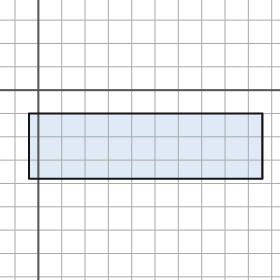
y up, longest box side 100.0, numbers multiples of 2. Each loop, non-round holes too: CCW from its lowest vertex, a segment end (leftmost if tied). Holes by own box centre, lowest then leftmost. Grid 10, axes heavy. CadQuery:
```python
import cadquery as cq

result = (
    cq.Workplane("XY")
    .moveTo(-4.0, -38.0)
    .lineTo(96.0, -38.0)
    .lineTo(96.0, -10.0)
    .lineTo(-4.0, -10.0)
    .close()
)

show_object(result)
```